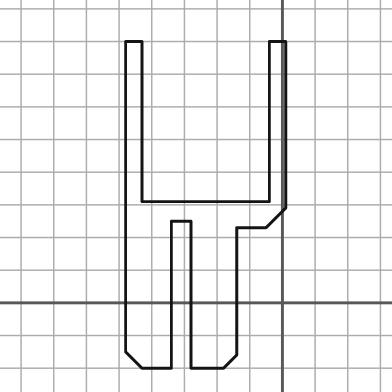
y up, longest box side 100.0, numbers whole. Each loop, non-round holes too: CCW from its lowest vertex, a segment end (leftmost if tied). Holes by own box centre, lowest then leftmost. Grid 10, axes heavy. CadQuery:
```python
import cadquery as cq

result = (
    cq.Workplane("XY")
    .moveTo(-43.0, -20.0)
    .lineTo(-34.0, -20.0)
    .lineTo(-34.0, 25.0)
    .lineTo(-28.0, 25.0)
    .lineTo(-28.0, -20.0)
    .lineTo(-18.0, -20.0)
    .lineTo(-14.0, -16.0)
    .lineTo(-14.0, 23.0)
    .lineTo(-5.0, 23.0)
    .lineTo(1.0, 29.0)
    .lineTo(1.0, 80.0)
    .lineTo(-4.0, 80.0)
    .lineTo(-4.0, 31.0)
    .lineTo(-43.0, 31.0)
    .lineTo(-43.0, 80.0)
    .lineTo(-48.0, 80.0)
    .lineTo(-48.0, -15.0)
    .close()
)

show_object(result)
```